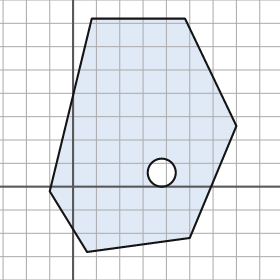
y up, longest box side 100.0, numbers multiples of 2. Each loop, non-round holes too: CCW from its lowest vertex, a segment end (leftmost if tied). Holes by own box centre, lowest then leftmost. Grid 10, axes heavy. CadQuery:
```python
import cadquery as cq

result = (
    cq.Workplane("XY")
    .moveTo(6.0, -28.0)
    .lineTo(50.0, -22.0)
    .lineTo(70.0, 26.0)
    .lineTo(48.0, 72.0)
    .lineTo(8.0, 72.0)
    .lineTo(-10.0, -2.0)
    .close()
    .moveTo(38.0, 6.0)
    .circle(6.0)
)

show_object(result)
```